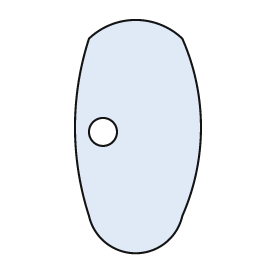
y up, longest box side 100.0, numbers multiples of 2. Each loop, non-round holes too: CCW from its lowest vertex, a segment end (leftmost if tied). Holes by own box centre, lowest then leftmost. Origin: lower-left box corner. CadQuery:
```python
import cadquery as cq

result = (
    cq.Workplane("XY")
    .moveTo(6.0, 16.0)
    .threePointArc((26.0, 0.0), (46.0, 16.0))
    .threePointArc((54.0, 54.0), (46.0, 92.0))
    .threePointArc((26.0, 100.0), (6.0, 92.0))
    .threePointArc((0.0, 54.0), (6.0, 16.0))
    .close()
    .moveTo(12.0, 52.0)
    .circle(6.0)
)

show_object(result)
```